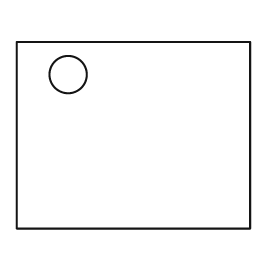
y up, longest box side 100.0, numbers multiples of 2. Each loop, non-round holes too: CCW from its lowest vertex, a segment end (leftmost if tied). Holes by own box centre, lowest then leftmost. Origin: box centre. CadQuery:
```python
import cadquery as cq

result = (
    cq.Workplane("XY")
    .moveTo(-50.0, -40.0)
    .lineTo(50.0, -40.0)
    .lineTo(50.0, 40.0)
    .lineTo(-50.0, 40.0)
    .close()
    .moveTo(-28.0, 26.0)
    .circle(8.0)
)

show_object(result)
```